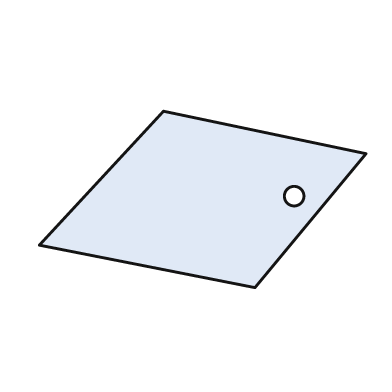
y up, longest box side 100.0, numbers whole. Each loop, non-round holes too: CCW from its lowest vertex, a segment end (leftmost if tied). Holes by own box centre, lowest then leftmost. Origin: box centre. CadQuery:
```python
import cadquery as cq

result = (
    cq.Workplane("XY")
    .moveTo(16.0, -27.0)
    .lineTo(50.0, 14.0)
    .lineTo(-12.0, 27.0)
    .lineTo(-50.0, -14.0)
    .close()
    .moveTo(28.0, 1.0)
    .circle(3.0)
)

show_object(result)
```